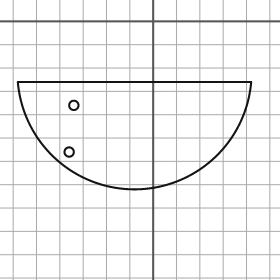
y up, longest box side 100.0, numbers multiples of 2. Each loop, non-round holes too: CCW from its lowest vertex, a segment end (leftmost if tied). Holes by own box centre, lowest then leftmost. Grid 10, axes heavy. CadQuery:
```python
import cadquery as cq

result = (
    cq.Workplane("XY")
    .moveTo(-58.0, -26.0)
    .threePointArc((-8.0, -72.0), (42.0, -26.0))
    .close()
    .moveTo(-36.0, -56.0)
    .circle(2.0)
    .moveTo(-34.0, -36.0)
    .circle(2.0)
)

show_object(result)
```